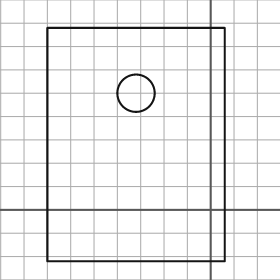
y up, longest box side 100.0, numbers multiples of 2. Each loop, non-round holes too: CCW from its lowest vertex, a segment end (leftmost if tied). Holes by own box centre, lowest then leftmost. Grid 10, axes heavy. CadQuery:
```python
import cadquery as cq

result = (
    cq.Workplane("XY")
    .moveTo(-70.0, -22.0)
    .lineTo(6.0, -22.0)
    .lineTo(6.0, 78.0)
    .lineTo(-70.0, 78.0)
    .close()
    .moveTo(-32.0, 50.0)
    .circle(8.0)
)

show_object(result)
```